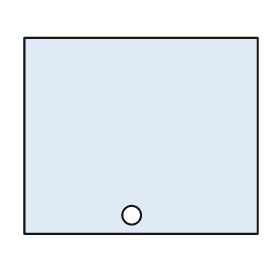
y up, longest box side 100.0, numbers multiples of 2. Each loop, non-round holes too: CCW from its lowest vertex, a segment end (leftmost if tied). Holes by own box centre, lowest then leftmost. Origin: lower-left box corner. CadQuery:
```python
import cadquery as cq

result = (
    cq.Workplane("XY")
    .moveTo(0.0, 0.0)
    .lineTo(100.0, 0.0)
    .lineTo(100.0, 84.0)
    .lineTo(0.0, 84.0)
    .close()
    .moveTo(46.0, 8.0)
    .circle(4.0)
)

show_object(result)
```